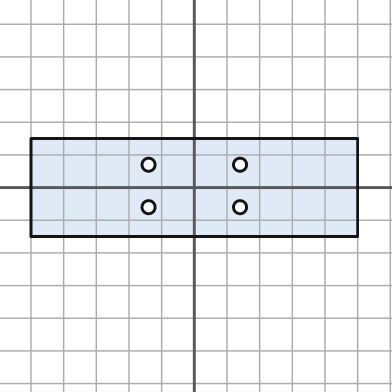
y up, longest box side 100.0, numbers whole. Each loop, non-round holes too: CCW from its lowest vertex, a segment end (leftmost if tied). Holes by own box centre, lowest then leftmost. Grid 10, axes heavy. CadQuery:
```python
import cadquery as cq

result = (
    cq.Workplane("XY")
    .moveTo(-50.0, -15.0)
    .lineTo(50.0, -15.0)
    .lineTo(50.0, 15.0)
    .lineTo(-50.0, 15.0)
    .close()
    .moveTo(-14.0, -6.0)
    .circle(2.0)
    .moveTo(14.0, -6.0)
    .circle(2.0)
    .moveTo(-14.0, 7.0)
    .circle(2.0)
    .moveTo(14.0, 7.0)
    .circle(2.0)
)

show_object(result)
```